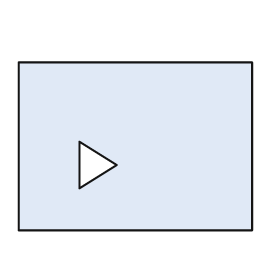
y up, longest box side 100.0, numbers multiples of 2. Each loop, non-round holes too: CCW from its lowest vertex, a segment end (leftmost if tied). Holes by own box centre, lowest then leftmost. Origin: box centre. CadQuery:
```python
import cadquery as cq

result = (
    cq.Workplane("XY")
    .moveTo(-50.0, -36.0)
    .lineTo(50.0, -36.0)
    .lineTo(50.0, 36.0)
    .lineTo(-50.0, 36.0)
    .close()
    .moveTo(-24.0, -18.0)
    .lineTo(-8.0, -8.0)
    .lineTo(-24.0, 2.0)
    .close()
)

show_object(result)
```